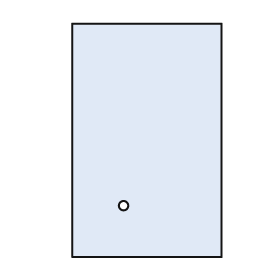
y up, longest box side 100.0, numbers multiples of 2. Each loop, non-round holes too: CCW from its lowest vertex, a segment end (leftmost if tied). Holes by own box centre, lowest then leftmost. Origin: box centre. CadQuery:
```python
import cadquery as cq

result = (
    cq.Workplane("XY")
    .moveTo(-32.0, -50.0)
    .lineTo(32.0, -50.0)
    .lineTo(32.0, 50.0)
    .lineTo(-32.0, 50.0)
    .close()
    .moveTo(-10.0, -28.0)
    .circle(2.0)
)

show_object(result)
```